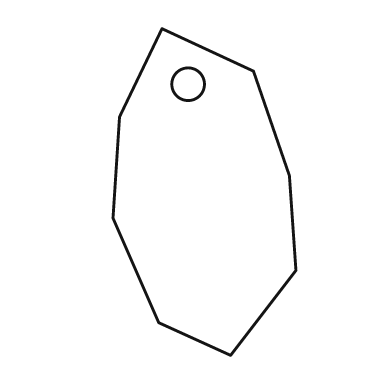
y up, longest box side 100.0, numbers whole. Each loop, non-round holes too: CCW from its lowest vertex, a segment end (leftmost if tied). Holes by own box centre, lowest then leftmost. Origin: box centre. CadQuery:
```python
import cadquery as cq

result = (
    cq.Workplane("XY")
    .moveTo(8.0, -50.0)
    .lineTo(28.0, -24.0)
    .lineTo(26.0, 5.0)
    .lineTo(15.0, 37.0)
    .lineTo(-13.0, 50.0)
    .lineTo(-26.0, 23.0)
    .lineTo(-28.0, -8.0)
    .lineTo(-14.0, -40.0)
    .close()
    .moveTo(-5.0, 33.0)
    .circle(5.0)
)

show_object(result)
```